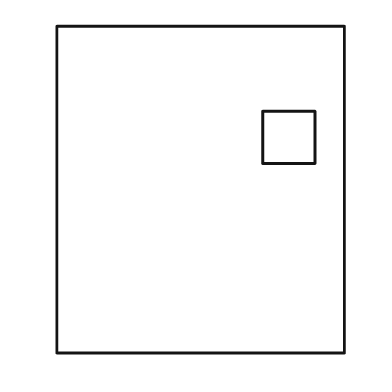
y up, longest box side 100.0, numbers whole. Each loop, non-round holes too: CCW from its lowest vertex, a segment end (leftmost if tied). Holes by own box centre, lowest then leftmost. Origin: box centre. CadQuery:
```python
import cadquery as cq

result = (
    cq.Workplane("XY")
    .moveTo(-44.0, -50.0)
    .lineTo(44.0, -50.0)
    .lineTo(44.0, 50.0)
    .lineTo(-44.0, 50.0)
    .close()
    .moveTo(19.0, 8.0)
    .lineTo(35.0, 8.0)
    .lineTo(35.0, 24.0)
    .lineTo(19.0, 24.0)
    .close()
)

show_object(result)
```